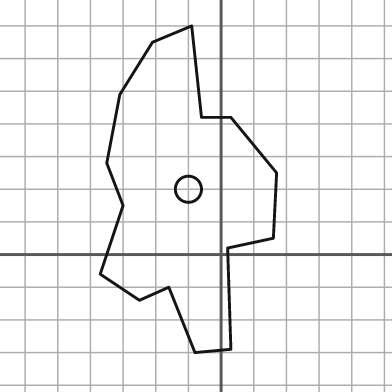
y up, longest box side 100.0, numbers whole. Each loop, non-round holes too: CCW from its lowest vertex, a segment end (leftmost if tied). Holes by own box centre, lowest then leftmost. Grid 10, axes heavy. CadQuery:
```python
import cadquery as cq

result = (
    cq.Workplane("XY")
    .moveTo(-8.0, -30.0)
    .lineTo(3.0, -29.0)
    .lineTo(2.0, 2.0)
    .lineTo(16.0, 5.0)
    .lineTo(17.0, 25.0)
    .lineTo(3.0, 42.0)
    .lineTo(-6.0, 42.0)
    .lineTo(-9.0, 70.0)
    .lineTo(-21.0, 65.0)
    .lineTo(-31.0, 49.0)
    .lineTo(-35.0, 28.0)
    .lineTo(-30.0, 15.0)
    .lineTo(-37.0, -6.0)
    .lineTo(-25.0, -14.0)
    .lineTo(-16.0, -10.0)
    .close()
    .moveTo(-10.0, 20.0)
    .circle(4.0)
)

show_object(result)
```